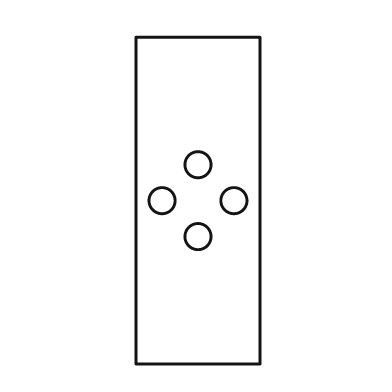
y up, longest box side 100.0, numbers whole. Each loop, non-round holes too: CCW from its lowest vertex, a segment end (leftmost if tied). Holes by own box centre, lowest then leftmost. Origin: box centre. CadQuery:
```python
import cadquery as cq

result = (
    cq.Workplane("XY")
    .moveTo(-19.0, -50.0)
    .lineTo(19.0, -50.0)
    .lineTo(19.0, 50.0)
    .lineTo(-19.0, 50.0)
    .close()
    .moveTo(0.0, -11.0)
    .circle(4.0)
    .moveTo(-11.0, 0.0)
    .circle(4.0)
    .moveTo(11.0, 0.0)
    .circle(4.0)
    .moveTo(0.0, 11.0)
    .circle(4.0)
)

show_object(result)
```